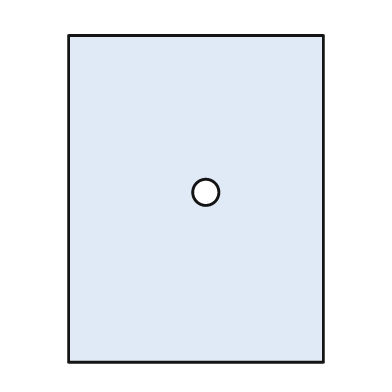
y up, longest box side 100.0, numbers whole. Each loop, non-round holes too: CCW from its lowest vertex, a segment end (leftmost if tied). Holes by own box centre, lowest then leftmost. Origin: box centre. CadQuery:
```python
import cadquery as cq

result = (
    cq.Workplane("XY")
    .moveTo(-39.0, -50.0)
    .lineTo(39.0, -50.0)
    .lineTo(39.0, 50.0)
    .lineTo(-39.0, 50.0)
    .close()
    .moveTo(3.0, 2.0)
    .circle(4.0)
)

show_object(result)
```